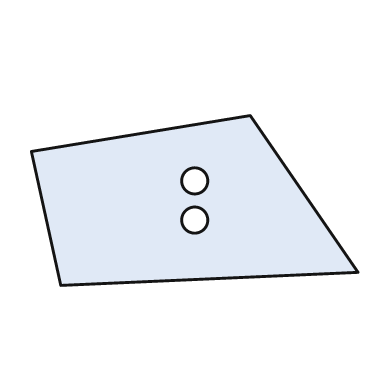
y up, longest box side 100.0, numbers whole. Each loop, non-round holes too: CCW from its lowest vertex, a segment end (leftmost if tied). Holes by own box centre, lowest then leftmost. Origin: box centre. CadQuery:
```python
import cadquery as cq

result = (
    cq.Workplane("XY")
    .moveTo(-41.0, -26.0)
    .lineTo(50.0, -22.0)
    .lineTo(17.0, 26.0)
    .lineTo(-50.0, 15.0)
    .close()
    .moveTo(0.0, -6.0)
    .circle(4.0)
    .moveTo(0.0, 6.0)
    .circle(4.0)
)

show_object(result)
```